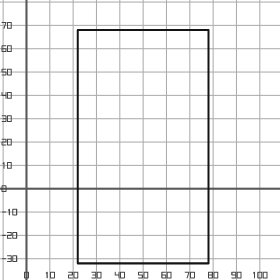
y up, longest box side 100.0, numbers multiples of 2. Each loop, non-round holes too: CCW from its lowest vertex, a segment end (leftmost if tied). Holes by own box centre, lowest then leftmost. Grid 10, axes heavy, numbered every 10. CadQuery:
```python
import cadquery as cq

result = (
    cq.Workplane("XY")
    .moveTo(22.0, -32.0)
    .lineTo(78.0, -32.0)
    .lineTo(78.0, 68.0)
    .lineTo(22.0, 68.0)
    .close()
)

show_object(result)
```